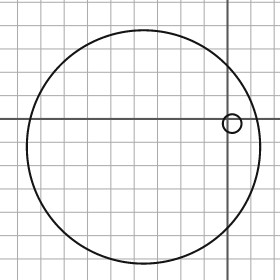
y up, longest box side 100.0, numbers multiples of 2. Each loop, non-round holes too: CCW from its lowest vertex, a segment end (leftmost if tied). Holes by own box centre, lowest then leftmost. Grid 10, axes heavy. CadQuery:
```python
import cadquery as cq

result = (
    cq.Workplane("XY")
    .moveTo(-36.0, -12.0)
    .circle(50.0)
    .moveTo(2.0, -2.0)
    .circle(4.0)
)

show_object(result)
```